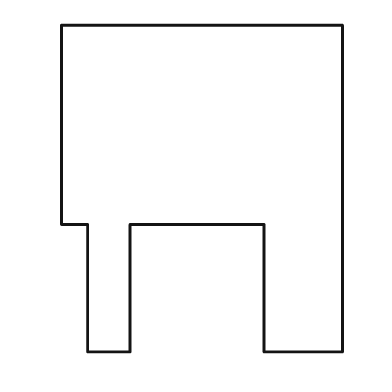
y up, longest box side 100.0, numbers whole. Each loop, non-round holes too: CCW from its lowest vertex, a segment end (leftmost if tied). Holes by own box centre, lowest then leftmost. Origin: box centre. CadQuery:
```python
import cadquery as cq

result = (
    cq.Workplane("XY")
    .moveTo(-35.0, -50.0)
    .lineTo(-22.0, -50.0)
    .lineTo(-22.0, -11.0)
    .lineTo(19.0, -11.0)
    .lineTo(19.0, -50.0)
    .lineTo(43.0, -50.0)
    .lineTo(43.0, 50.0)
    .lineTo(-43.0, 50.0)
    .lineTo(-43.0, -11.0)
    .lineTo(-35.0, -11.0)
    .close()
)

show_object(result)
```